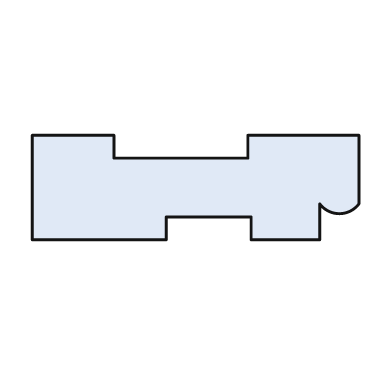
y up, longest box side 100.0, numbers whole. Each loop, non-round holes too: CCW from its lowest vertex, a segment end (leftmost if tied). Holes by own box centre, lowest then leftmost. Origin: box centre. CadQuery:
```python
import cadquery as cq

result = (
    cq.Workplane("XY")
    .moveTo(-50.0, -16.0)
    .lineTo(-9.0, -16.0)
    .lineTo(-9.0, -9.0)
    .lineTo(17.0, -9.0)
    .lineTo(17.0, -16.0)
    .lineTo(38.0, -16.0)
    .lineTo(38.0, -5.0)
    .threePointArc((44.0, -8.0), (50.0, -5.0))
    .lineTo(50.0, 16.0)
    .lineTo(16.0, 16.0)
    .lineTo(16.0, 9.0)
    .lineTo(-25.0, 9.0)
    .lineTo(-25.0, 16.0)
    .lineTo(-50.0, 16.0)
    .close()
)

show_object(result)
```